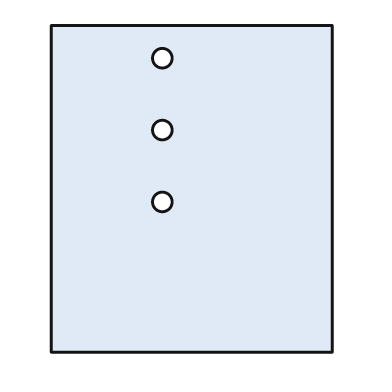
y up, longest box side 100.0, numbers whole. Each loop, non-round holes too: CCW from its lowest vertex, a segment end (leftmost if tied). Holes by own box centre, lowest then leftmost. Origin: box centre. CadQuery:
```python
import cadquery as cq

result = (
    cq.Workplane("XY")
    .moveTo(-43.0, -50.0)
    .lineTo(43.0, -50.0)
    .lineTo(43.0, 50.0)
    .lineTo(-43.0, 50.0)
    .close()
    .moveTo(-9.0, -4.0)
    .circle(3.0)
    .moveTo(-9.0, 18.0)
    .circle(3.0)
    .moveTo(-9.0, 40.0)
    .circle(3.0)
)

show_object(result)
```